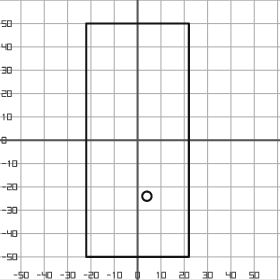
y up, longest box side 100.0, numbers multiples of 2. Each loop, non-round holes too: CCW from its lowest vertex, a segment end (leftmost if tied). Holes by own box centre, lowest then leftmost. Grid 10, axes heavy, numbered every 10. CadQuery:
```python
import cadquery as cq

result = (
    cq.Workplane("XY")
    .moveTo(-22.0, -50.0)
    .lineTo(22.0, -50.0)
    .lineTo(22.0, 50.0)
    .lineTo(-22.0, 50.0)
    .close()
    .moveTo(4.0, -24.0)
    .circle(2.0)
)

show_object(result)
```